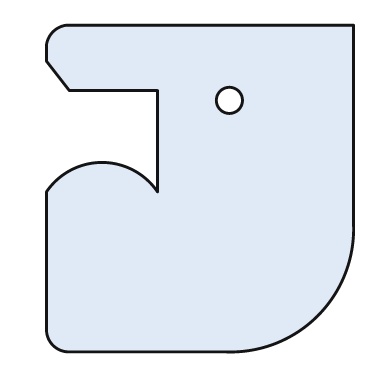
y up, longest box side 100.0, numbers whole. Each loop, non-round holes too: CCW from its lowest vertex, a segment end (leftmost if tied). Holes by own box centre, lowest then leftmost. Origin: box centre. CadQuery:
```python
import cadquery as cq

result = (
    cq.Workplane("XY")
    .moveTo(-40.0, -50.0)
    .lineTo(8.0, -50.0)
    .threePointArc((36.0, -39.0), (47.0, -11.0))
    .lineTo(47.0, 50.0)
    .lineTo(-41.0, 50.0)
    .threePointArc((-45.0, 48.0), (-47.0, 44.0))
    .lineTo(-47.0, 39.0)
    .lineTo(-40.0, 30.0)
    .lineTo(-13.0, 30.0)
    .lineTo(-13.0, -1.0)
    .threePointArc((-30.0, 8.0), (-47.0, -1.0))
    .lineTo(-47.0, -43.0)
    .threePointArc((-45.0, -48.0), (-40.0, -50.0))
    .close()
    .moveTo(9.0, 27.0)
    .circle(4.0)
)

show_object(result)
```